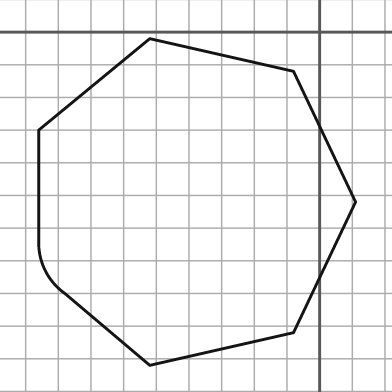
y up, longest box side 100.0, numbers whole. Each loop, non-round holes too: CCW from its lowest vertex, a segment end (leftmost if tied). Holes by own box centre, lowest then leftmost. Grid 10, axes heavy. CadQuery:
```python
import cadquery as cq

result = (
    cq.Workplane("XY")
    .moveTo(-52.0, -102.0)
    .lineTo(-8.0, -92.0)
    .lineTo(11.0, -52.0)
    .lineTo(-8.0, -12.0)
    .lineTo(-52.0, -2.0)
    .lineTo(-86.0, -30.0)
    .lineTo(-86.0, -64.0)
    .threePointArc((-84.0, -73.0), (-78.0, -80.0))
    .close()
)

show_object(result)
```